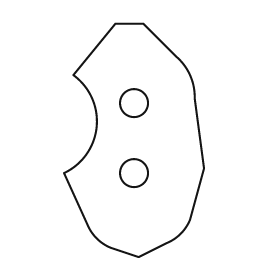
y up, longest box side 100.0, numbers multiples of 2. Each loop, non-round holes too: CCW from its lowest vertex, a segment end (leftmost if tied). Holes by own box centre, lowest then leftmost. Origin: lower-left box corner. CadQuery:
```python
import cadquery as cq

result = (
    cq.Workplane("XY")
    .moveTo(32.0, 0.0)
    .lineTo(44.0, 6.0)
    .threePointArc((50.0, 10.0), (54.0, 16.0))
    .lineTo(60.0, 38.0)
    .lineTo(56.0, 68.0)
    .threePointArc((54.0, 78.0), (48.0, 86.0))
    .lineTo(34.0, 100.0)
    .lineTo(22.0, 100.0)
    .lineTo(4.0, 78.0)
    .threePointArc((14.0, 56.0), (0.0, 36.0))
    .lineTo(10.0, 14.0)
    .threePointArc((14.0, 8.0), (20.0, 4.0))
    .close()
    .moveTo(30.0, 36.0)
    .circle(6.0)
    .moveTo(30.0, 66.0)
    .circle(6.0)
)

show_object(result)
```